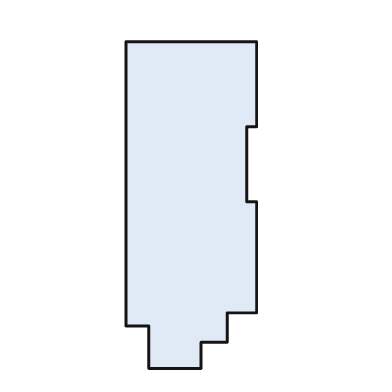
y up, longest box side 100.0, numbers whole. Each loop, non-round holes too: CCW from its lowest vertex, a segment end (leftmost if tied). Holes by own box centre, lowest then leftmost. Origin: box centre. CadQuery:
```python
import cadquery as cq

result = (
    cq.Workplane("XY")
    .moveTo(-13.0, -50.0)
    .lineTo(3.0, -50.0)
    .lineTo(3.0, -42.0)
    .lineTo(11.0, -42.0)
    .lineTo(11.0, -33.0)
    .lineTo(20.0, -33.0)
    .lineTo(20.0, 1.0)
    .lineTo(17.0, 1.0)
    .lineTo(17.0, 24.0)
    .lineTo(20.0, 24.0)
    .lineTo(20.0, 50.0)
    .lineTo(-20.0, 50.0)
    .lineTo(-20.0, -37.0)
    .lineTo(-13.0, -37.0)
    .close()
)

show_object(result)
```